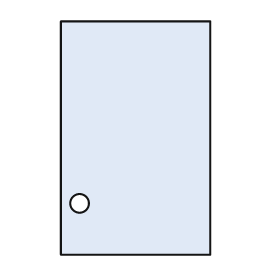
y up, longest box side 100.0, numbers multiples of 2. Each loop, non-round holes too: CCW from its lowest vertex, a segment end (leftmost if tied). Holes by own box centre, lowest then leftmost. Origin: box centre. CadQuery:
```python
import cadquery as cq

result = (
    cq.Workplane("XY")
    .moveTo(-32.0, -50.0)
    .lineTo(32.0, -50.0)
    .lineTo(32.0, 50.0)
    .lineTo(-32.0, 50.0)
    .close()
    .moveTo(-24.0, -28.0)
    .circle(4.0)
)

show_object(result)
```